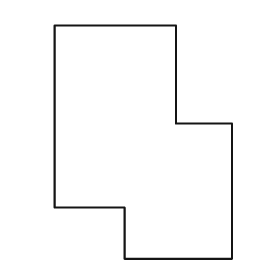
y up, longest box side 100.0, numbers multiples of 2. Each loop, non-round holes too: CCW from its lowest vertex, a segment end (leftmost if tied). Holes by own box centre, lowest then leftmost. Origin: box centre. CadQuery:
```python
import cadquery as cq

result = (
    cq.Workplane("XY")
    .moveTo(-8.0, -50.0)
    .lineTo(38.0, -50.0)
    .lineTo(38.0, 8.0)
    .lineTo(14.0, 8.0)
    .lineTo(14.0, 50.0)
    .lineTo(-38.0, 50.0)
    .lineTo(-38.0, -28.0)
    .lineTo(-8.0, -28.0)
    .close()
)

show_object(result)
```